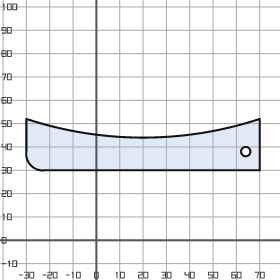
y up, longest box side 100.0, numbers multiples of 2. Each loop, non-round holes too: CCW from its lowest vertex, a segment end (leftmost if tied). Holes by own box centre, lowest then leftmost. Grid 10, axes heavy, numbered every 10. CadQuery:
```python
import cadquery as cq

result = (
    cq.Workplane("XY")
    .moveTo(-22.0, 30.0)
    .lineTo(70.0, 30.0)
    .lineTo(70.0, 52.0)
    .threePointArc((20.0, 44.0), (-30.0, 52.0))
    .lineTo(-30.0, 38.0)
    .threePointArc((-28.0, 32.0), (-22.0, 30.0))
    .close()
    .moveTo(64.0, 38.0)
    .circle(2.0)
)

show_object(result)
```